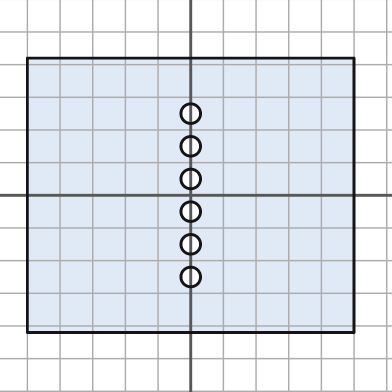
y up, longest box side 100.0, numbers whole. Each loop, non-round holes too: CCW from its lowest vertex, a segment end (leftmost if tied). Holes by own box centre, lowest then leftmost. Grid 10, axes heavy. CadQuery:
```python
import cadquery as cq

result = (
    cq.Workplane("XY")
    .moveTo(-50.0, -42.0)
    .lineTo(50.0, -42.0)
    .lineTo(50.0, 42.0)
    .lineTo(-50.0, 42.0)
    .close()
    .moveTo(0.0, -25.0)
    .circle(3.0)
    .moveTo(0.0, -15.0)
    .circle(3.0)
    .moveTo(0.0, -5.0)
    .circle(3.0)
    .moveTo(0.0, 5.0)
    .circle(3.0)
    .moveTo(0.0, 15.0)
    .circle(3.0)
    .moveTo(0.0, 25.0)
    .circle(3.0)
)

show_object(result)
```